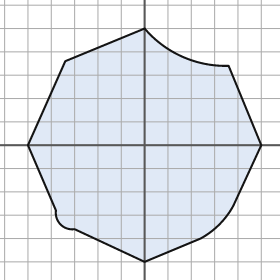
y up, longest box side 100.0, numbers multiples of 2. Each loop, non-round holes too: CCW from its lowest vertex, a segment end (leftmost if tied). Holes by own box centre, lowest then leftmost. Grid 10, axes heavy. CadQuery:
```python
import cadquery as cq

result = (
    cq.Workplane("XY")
    .moveTo(0.0, -50.0)
    .lineTo(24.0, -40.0)
    .threePointArc((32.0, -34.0), (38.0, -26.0))
    .lineTo(50.0, 0.0)
    .lineTo(36.0, 34.0)
    .threePointArc((16.0, 38.0), (0.0, 50.0))
    .lineTo(-34.0, 36.0)
    .lineTo(-50.0, 0.0)
    .lineTo(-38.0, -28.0)
    .threePointArc((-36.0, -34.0), (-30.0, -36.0))
    .close()
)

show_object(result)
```